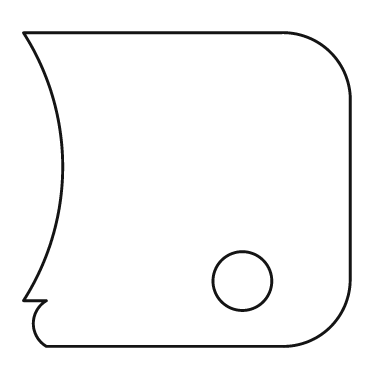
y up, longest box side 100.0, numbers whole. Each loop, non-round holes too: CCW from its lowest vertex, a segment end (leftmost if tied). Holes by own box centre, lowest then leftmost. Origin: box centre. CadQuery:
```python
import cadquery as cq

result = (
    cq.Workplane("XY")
    .moveTo(-43.0, -48.0)
    .lineTo(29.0, -48.0)
    .threePointArc((44.0, -42.0), (50.0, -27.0))
    .lineTo(50.0, 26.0)
    .threePointArc((44.0, 42.0), (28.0, 48.0))
    .lineTo(-50.0, 48.0)
    .threePointArc((-38.0, 7.0), (-50.0, -34.0))
    .lineTo(-43.0, -34.0)
    .threePointArc((-47.0, -41.0), (-43.0, -48.0))
    .close()
    .moveTo(17.0, -28.0)
    .circle(9.0)
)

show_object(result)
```